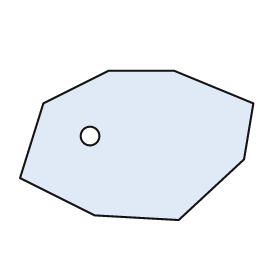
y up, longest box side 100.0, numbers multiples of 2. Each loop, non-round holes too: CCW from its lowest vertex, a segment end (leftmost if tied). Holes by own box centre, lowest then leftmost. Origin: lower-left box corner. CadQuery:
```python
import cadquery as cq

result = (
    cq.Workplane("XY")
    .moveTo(68.0, 0.0)
    .lineTo(96.0, 26.0)
    .lineTo(100.0, 50.0)
    .lineTo(66.0, 64.0)
    .lineTo(38.0, 64.0)
    .lineTo(10.0, 50.0)
    .lineTo(0.0, 18.0)
    .lineTo(32.0, 2.0)
    .close()
    .moveTo(30.0, 36.0)
    .circle(4.0)
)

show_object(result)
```